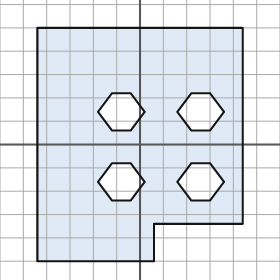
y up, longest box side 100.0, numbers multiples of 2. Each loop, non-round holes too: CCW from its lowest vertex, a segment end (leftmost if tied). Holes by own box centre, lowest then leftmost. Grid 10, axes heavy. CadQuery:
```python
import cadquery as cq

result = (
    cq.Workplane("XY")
    .moveTo(-44.0, -50.0)
    .lineTo(6.0, -50.0)
    .lineTo(6.0, -34.0)
    .lineTo(44.0, -34.0)
    .lineTo(44.0, 50.0)
    .lineTo(-44.0, 50.0)
    .close()
    .moveTo(-12.0, -24.0)
    .lineTo(-4.0, -24.0)
    .lineTo(2.0, -16.0)
    .lineTo(-4.0, -8.0)
    .lineTo(-12.0, -8.0)
    .lineTo(-18.0, -16.0)
    .close()
    .moveTo(22.0, -24.0)
    .lineTo(30.0, -24.0)
    .lineTo(36.0, -16.0)
    .lineTo(30.0, -8.0)
    .lineTo(22.0, -8.0)
    .lineTo(16.0, -16.0)
    .close()
    .moveTo(-12.0, 6.0)
    .lineTo(-4.0, 6.0)
    .lineTo(2.0, 14.0)
    .lineTo(-4.0, 22.0)
    .lineTo(-12.0, 22.0)
    .lineTo(-18.0, 14.0)
    .close()
    .moveTo(22.0, 6.0)
    .lineTo(30.0, 6.0)
    .lineTo(36.0, 14.0)
    .lineTo(30.0, 22.0)
    .lineTo(22.0, 22.0)
    .lineTo(16.0, 14.0)
    .close()
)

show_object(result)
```